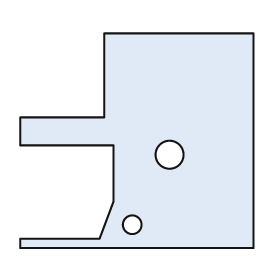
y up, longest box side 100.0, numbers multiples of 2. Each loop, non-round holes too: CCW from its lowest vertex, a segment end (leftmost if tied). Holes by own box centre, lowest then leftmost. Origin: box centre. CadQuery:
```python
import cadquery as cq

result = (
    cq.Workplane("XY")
    .moveTo(-50.0, -46.0)
    .lineTo(50.0, -46.0)
    .lineTo(50.0, 46.0)
    .lineTo(-14.0, 46.0)
    .lineTo(-14.0, 10.0)
    .lineTo(-50.0, 10.0)
    .lineTo(-50.0, -2.0)
    .lineTo(-10.0, -2.0)
    .lineTo(-10.0, -26.0)
    .lineTo(-16.0, -42.0)
    .lineTo(-50.0, -42.0)
    .close()
    .moveTo(-2.0, -36.0)
    .circle(4.0)
    .moveTo(14.0, -6.0)
    .circle(6.0)
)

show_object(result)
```